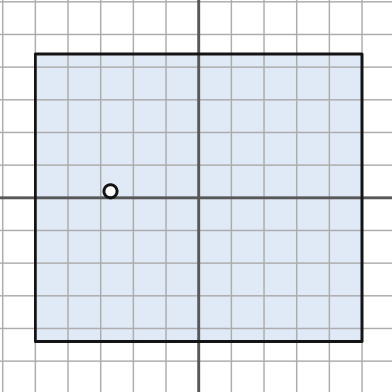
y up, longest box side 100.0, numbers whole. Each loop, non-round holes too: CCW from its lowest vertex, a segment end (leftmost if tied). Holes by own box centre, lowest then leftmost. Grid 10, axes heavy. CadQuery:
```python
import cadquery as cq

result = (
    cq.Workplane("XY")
    .moveTo(-50.0, -44.0)
    .lineTo(50.0, -44.0)
    .lineTo(50.0, 44.0)
    .lineTo(-50.0, 44.0)
    .close()
    .moveTo(-27.0, 2.0)
    .circle(2.0)
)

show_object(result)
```